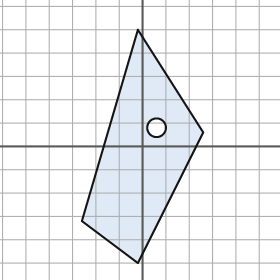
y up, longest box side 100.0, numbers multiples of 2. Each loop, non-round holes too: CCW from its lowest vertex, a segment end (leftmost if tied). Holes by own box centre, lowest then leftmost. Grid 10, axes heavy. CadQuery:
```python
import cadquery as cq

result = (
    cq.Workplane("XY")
    .moveTo(-2.0, -50.0)
    .lineTo(26.0, 6.0)
    .lineTo(-2.0, 50.0)
    .lineTo(-26.0, -32.0)
    .close()
    .moveTo(6.0, 8.0)
    .circle(4.0)
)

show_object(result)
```